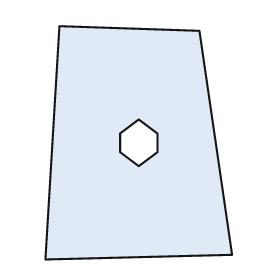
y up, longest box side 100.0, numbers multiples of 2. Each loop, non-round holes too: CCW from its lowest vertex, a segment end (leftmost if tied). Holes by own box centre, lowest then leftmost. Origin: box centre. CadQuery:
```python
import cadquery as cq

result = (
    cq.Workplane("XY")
    .moveTo(-40.0, -50.0)
    .lineTo(40.0, -48.0)
    .lineTo(26.0, 48.0)
    .lineTo(-34.0, 50.0)
    .close()
    .moveTo(0.0, -10.0)
    .lineTo(8.0, -4.0)
    .lineTo(8.0, 4.0)
    .lineTo(0.0, 10.0)
    .lineTo(-8.0, 4.0)
    .lineTo(-8.0, -4.0)
    .close()
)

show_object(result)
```